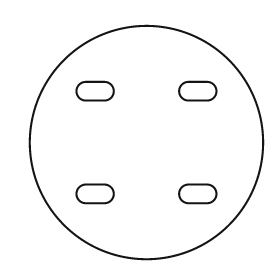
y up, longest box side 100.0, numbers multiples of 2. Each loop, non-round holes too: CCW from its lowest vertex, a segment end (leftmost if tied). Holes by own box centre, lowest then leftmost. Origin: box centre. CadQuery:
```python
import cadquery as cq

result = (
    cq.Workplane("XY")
    .moveTo(0.0, 0.0)
    .circle(50.0)
    .moveTo(-26.0, -26.0)
    .lineTo(-18.0, -26.0)
    .threePointArc((-14.0, -22.0), (-18.0, -18.0))
    .lineTo(-26.0, -18.0)
    .threePointArc((-30.0, -22.0), (-26.0, -26.0))
    .close()
    .moveTo(18.0, -26.0)
    .lineTo(26.0, -26.0)
    .threePointArc((30.0, -22.0), (26.0, -18.0))
    .lineTo(18.0, -18.0)
    .threePointArc((14.0, -22.0), (18.0, -26.0))
    .close()
    .moveTo(-26.0, 18.0)
    .lineTo(-18.0, 18.0)
    .threePointArc((-14.0, 22.0), (-18.0, 26.0))
    .lineTo(-26.0, 26.0)
    .threePointArc((-30.0, 22.0), (-26.0, 18.0))
    .close()
    .moveTo(18.0, 18.0)
    .lineTo(26.0, 18.0)
    .threePointArc((30.0, 22.0), (26.0, 26.0))
    .lineTo(18.0, 26.0)
    .threePointArc((14.0, 22.0), (18.0, 18.0))
    .close()
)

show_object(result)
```